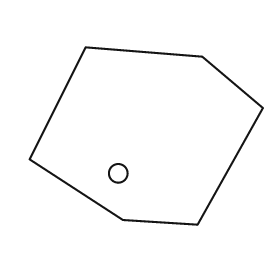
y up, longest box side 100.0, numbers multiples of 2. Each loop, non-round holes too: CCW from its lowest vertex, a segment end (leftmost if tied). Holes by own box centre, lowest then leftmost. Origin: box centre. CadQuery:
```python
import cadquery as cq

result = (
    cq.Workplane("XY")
    .moveTo(22.0, -38.0)
    .lineTo(50.0, 12.0)
    .lineTo(24.0, 34.0)
    .lineTo(-26.0, 38.0)
    .lineTo(-50.0, -10.0)
    .lineTo(-10.0, -36.0)
    .close()
    .moveTo(-12.0, -16.0)
    .circle(4.0)
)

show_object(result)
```